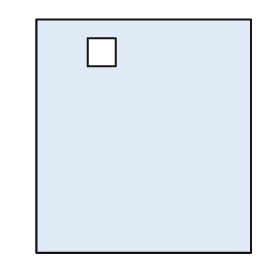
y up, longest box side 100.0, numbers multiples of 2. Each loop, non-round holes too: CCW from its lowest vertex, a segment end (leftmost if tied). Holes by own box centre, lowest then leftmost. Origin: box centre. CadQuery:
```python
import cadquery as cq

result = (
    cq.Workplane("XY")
    .moveTo(-46.0, -50.0)
    .lineTo(46.0, -50.0)
    .lineTo(46.0, 50.0)
    .lineTo(-46.0, 50.0)
    .close()
    .moveTo(-24.0, 30.0)
    .lineTo(-12.0, 30.0)
    .lineTo(-12.0, 42.0)
    .lineTo(-24.0, 42.0)
    .close()
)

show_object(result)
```